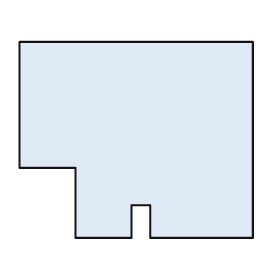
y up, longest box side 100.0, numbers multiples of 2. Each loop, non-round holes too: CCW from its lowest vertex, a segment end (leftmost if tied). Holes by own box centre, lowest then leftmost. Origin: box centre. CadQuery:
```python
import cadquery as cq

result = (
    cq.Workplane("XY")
    .moveTo(-26.0, -42.0)
    .lineTo(-2.0, -42.0)
    .lineTo(-2.0, -28.0)
    .lineTo(6.0, -28.0)
    .lineTo(6.0, -42.0)
    .lineTo(50.0, -42.0)
    .lineTo(50.0, 42.0)
    .lineTo(-50.0, 42.0)
    .lineTo(-50.0, -12.0)
    .lineTo(-26.0, -12.0)
    .close()
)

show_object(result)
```